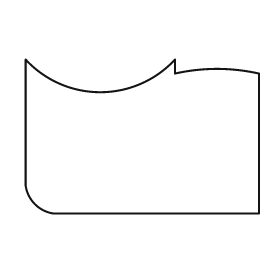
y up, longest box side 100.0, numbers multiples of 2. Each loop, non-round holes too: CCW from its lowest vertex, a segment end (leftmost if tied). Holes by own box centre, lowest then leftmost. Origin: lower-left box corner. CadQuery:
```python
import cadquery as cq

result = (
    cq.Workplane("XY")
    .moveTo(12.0, 0.0)
    .lineTo(100.0, 0.0)
    .lineTo(100.0, 60.0)
    .threePointArc((82.0, 62.0), (64.0, 60.0))
    .lineTo(64.0, 66.0)
    .threePointArc((32.0, 52.0), (0.0, 66.0))
    .lineTo(0.0, 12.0)
    .threePointArc((4.0, 4.0), (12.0, 0.0))
    .close()
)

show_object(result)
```